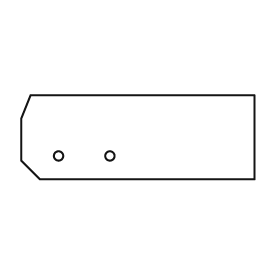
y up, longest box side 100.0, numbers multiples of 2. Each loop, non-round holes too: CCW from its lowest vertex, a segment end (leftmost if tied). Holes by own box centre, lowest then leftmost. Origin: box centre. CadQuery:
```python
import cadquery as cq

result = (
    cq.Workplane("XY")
    .moveTo(-42.0, -18.0)
    .lineTo(50.0, -18.0)
    .lineTo(50.0, 18.0)
    .lineTo(-46.0, 18.0)
    .lineTo(-50.0, 8.0)
    .lineTo(-50.0, -10.0)
    .close()
    .moveTo(-34.0, -8.0)
    .circle(2.0)
    .moveTo(-12.0, -8.0)
    .circle(2.0)
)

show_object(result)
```